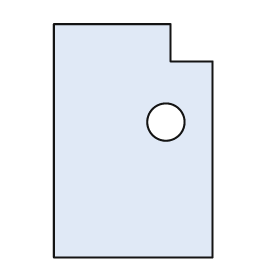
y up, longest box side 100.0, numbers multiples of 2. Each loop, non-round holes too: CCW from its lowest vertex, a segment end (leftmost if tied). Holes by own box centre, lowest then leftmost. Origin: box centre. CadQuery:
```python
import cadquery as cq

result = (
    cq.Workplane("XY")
    .moveTo(-34.0, -50.0)
    .lineTo(34.0, -50.0)
    .lineTo(34.0, 34.0)
    .lineTo(16.0, 34.0)
    .lineTo(16.0, 50.0)
    .lineTo(-34.0, 50.0)
    .close()
    .moveTo(14.0, 8.0)
    .circle(8.0)
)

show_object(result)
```